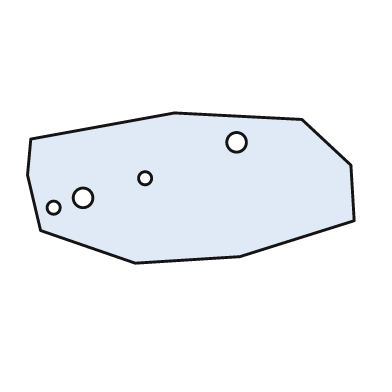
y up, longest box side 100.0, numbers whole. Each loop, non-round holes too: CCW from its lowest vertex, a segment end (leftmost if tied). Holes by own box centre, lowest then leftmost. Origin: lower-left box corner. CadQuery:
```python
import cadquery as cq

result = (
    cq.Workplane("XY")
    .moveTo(33.0, 0.0)
    .lineTo(65.0, 2.0)
    .lineTo(100.0, 13.0)
    .lineTo(99.0, 30.0)
    .lineTo(84.0, 44.0)
    .lineTo(45.0, 46.0)
    .lineTo(1.0, 38.0)
    .lineTo(0.0, 27.0)
    .lineTo(4.0, 10.0)
    .close()
    .moveTo(8.0, 17.0)
    .circle(2.0)
    .moveTo(17.0, 20.0)
    .circle(3.0)
    .moveTo(36.0, 26.0)
    .circle(2.0)
    .moveTo(64.0, 37.0)
    .circle(3.0)
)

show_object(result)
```